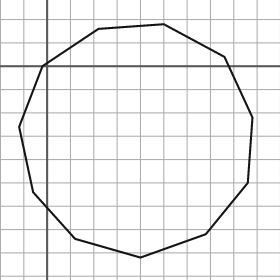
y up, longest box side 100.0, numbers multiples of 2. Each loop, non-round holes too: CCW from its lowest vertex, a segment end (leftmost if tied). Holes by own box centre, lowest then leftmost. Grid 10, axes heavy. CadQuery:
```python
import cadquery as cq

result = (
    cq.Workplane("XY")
    .moveTo(40.0, -82.0)
    .lineTo(68.0, -72.0)
    .lineTo(86.0, -50.0)
    .lineTo(88.0, -22.0)
    .lineTo(76.0, 4.0)
    .lineTo(50.0, 18.0)
    .lineTo(22.0, 16.0)
    .lineTo(-2.0, 0.0)
    .lineTo(-12.0, -26.0)
    .lineTo(-6.0, -54.0)
    .lineTo(12.0, -74.0)
    .close()
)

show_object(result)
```